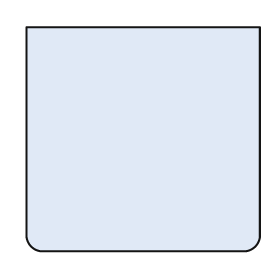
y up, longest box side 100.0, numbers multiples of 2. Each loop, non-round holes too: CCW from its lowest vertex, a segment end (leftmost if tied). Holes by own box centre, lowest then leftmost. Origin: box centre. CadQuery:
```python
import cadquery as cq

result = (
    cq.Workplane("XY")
    .moveTo(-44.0, -48.0)
    .lineTo(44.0, -48.0)
    .threePointArc((48.0, -46.0), (50.0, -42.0))
    .lineTo(50.0, 48.0)
    .lineTo(-50.0, 48.0)
    .lineTo(-50.0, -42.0)
    .threePointArc((-48.0, -46.0), (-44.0, -48.0))
    .close()
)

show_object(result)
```